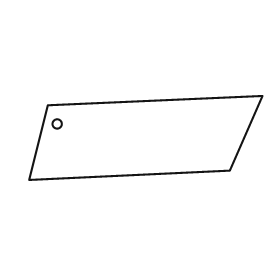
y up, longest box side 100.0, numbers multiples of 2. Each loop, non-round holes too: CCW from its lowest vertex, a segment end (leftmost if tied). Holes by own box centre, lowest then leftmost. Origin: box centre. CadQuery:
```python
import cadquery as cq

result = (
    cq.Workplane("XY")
    .moveTo(-50.0, -18.0)
    .lineTo(36.0, -14.0)
    .lineTo(50.0, 18.0)
    .lineTo(-42.0, 14.0)
    .close()
    .moveTo(-38.0, 6.0)
    .circle(2.0)
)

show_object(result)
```